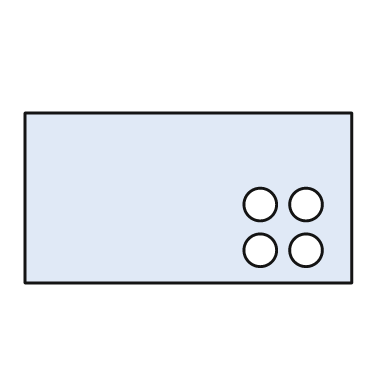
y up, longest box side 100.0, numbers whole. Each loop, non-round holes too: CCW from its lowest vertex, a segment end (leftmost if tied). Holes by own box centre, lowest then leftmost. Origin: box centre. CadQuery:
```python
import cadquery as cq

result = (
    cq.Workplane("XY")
    .moveTo(-50.0, -26.0)
    .lineTo(50.0, -26.0)
    .lineTo(50.0, 26.0)
    .lineTo(-50.0, 26.0)
    .close()
    .moveTo(22.0, -16.0)
    .circle(5.0)
    .moveTo(36.0, -16.0)
    .circle(5.0)
    .moveTo(22.0, -2.0)
    .circle(5.0)
    .moveTo(36.0, -2.0)
    .circle(5.0)
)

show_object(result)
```